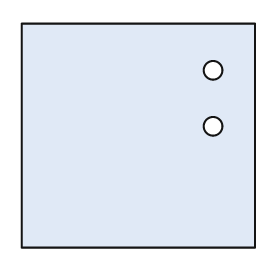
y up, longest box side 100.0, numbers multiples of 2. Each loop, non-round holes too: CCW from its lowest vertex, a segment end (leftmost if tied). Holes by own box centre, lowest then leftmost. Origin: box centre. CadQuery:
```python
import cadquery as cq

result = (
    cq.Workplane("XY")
    .moveTo(-50.0, -48.0)
    .lineTo(50.0, -48.0)
    .lineTo(50.0, 48.0)
    .lineTo(-50.0, 48.0)
    .close()
    .moveTo(32.0, 4.0)
    .circle(4.0)
    .moveTo(32.0, 28.0)
    .circle(4.0)
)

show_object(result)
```